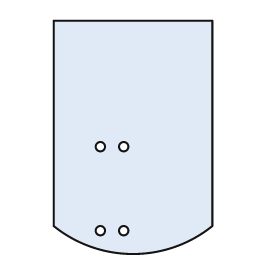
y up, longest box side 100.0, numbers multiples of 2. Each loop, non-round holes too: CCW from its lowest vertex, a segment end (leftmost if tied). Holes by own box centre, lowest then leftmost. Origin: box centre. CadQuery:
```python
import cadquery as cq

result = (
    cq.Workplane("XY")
    .moveTo(-34.0, -38.0)
    .threePointArc((0.0, -50.0), (34.0, -38.0))
    .lineTo(34.0, 50.0)
    .lineTo(-34.0, 50.0)
    .close()
    .moveTo(-14.0, -40.0)
    .circle(2.0)
    .moveTo(-4.0, -40.0)
    .circle(2.0)
    .moveTo(-14.0, -4.0)
    .circle(2.0)
    .moveTo(-4.0, -4.0)
    .circle(2.0)
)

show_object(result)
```